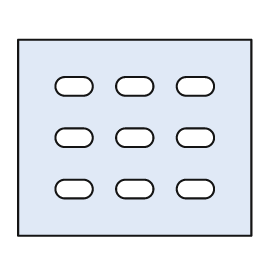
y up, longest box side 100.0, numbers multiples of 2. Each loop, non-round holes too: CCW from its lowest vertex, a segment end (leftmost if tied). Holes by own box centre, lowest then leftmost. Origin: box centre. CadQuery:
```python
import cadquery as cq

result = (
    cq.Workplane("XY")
    .moveTo(-50.0, -42.0)
    .lineTo(50.0, -42.0)
    .lineTo(50.0, 42.0)
    .lineTo(-50.0, 42.0)
    .close()
    .moveTo(-30.0, -26.0)
    .lineTo(-22.0, -26.0)
    .threePointArc((-18.0, -22.0), (-22.0, -18.0))
    .lineTo(-30.0, -18.0)
    .threePointArc((-34.0, -22.0), (-30.0, -26.0))
    .close()
    .moveTo(-4.0, -26.0)
    .lineTo(4.0, -26.0)
    .threePointArc((8.0, -22.0), (4.0, -18.0))
    .lineTo(-4.0, -18.0)
    .threePointArc((-8.0, -22.0), (-4.0, -26.0))
    .close()
    .moveTo(22.0, -26.0)
    .lineTo(30.0, -26.0)
    .threePointArc((34.0, -22.0), (30.0, -18.0))
    .lineTo(22.0, -18.0)
    .threePointArc((18.0, -22.0), (22.0, -26.0))
    .close()
    .moveTo(-30.0, -4.0)
    .lineTo(-22.0, -4.0)
    .threePointArc((-18.0, 0.0), (-22.0, 4.0))
    .lineTo(-30.0, 4.0)
    .threePointArc((-34.0, 0.0), (-30.0, -4.0))
    .close()
    .moveTo(-4.0, -4.0)
    .lineTo(4.0, -4.0)
    .threePointArc((8.0, 0.0), (4.0, 4.0))
    .lineTo(-4.0, 4.0)
    .threePointArc((-8.0, 0.0), (-4.0, -4.0))
    .close()
    .moveTo(22.0, -4.0)
    .lineTo(30.0, -4.0)
    .threePointArc((34.0, 0.0), (30.0, 4.0))
    .lineTo(22.0, 4.0)
    .threePointArc((18.0, 0.0), (22.0, -4.0))
    .close()
    .moveTo(-30.0, 18.0)
    .lineTo(-22.0, 18.0)
    .threePointArc((-18.0, 22.0), (-22.0, 26.0))
    .lineTo(-30.0, 26.0)
    .threePointArc((-34.0, 22.0), (-30.0, 18.0))
    .close()
    .moveTo(-4.0, 18.0)
    .lineTo(4.0, 18.0)
    .threePointArc((8.0, 22.0), (4.0, 26.0))
    .lineTo(-4.0, 26.0)
    .threePointArc((-8.0, 22.0), (-4.0, 18.0))
    .close()
    .moveTo(22.0, 18.0)
    .lineTo(30.0, 18.0)
    .threePointArc((34.0, 22.0), (30.0, 26.0))
    .lineTo(22.0, 26.0)
    .threePointArc((18.0, 22.0), (22.0, 18.0))
    .close()
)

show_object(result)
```